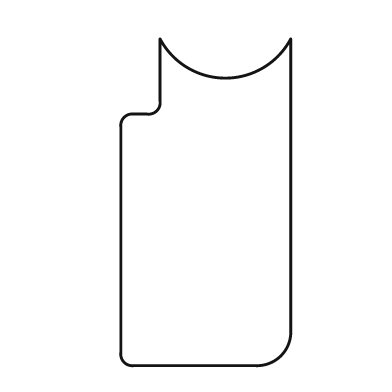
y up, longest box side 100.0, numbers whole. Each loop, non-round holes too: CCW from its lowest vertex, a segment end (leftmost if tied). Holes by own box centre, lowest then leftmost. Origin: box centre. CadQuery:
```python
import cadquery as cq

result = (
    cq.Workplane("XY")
    .moveTo(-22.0, -50.0)
    .lineTo(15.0, -50.0)
    .threePointArc((23.0, -47.0), (26.0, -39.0))
    .lineTo(26.0, 50.0)
    .threePointArc((6.0, 38.0), (-14.0, 50.0))
    .lineTo(-14.0, 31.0)
    .threePointArc((-15.0, 28.0), (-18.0, 27.0))
    .lineTo(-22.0, 27.0)
    .threePointArc((-25.0, 26.0), (-26.0, 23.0))
    .lineTo(-26.0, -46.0)
    .threePointArc((-25.0, -49.0), (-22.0, -50.0))
    .close()
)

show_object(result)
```